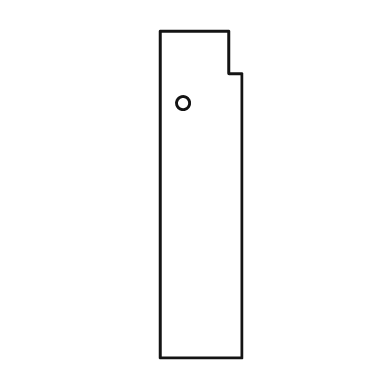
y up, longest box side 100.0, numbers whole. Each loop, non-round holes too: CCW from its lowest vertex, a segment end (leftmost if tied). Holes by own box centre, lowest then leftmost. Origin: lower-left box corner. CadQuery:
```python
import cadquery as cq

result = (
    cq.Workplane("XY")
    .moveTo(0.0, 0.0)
    .lineTo(25.0, 0.0)
    .lineTo(25.0, 87.0)
    .lineTo(21.0, 87.0)
    .lineTo(21.0, 100.0)
    .lineTo(0.0, 100.0)
    .close()
    .moveTo(7.0, 78.0)
    .circle(2.0)
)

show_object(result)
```